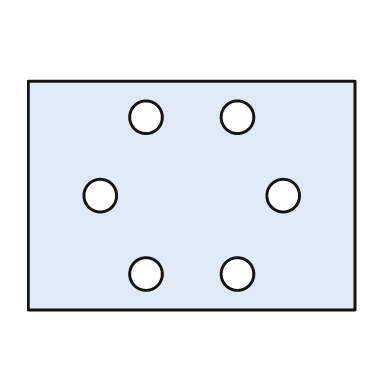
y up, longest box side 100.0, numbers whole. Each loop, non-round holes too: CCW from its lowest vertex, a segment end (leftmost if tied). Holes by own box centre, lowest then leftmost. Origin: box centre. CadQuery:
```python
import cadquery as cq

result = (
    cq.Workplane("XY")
    .moveTo(-50.0, -35.0)
    .lineTo(50.0, -35.0)
    .lineTo(50.0, 35.0)
    .lineTo(-50.0, 35.0)
    .close()
    .moveTo(-14.0, -24.0)
    .circle(5.0)
    .moveTo(14.0, -24.0)
    .circle(5.0)
    .moveTo(-28.0, 0.0)
    .circle(5.0)
    .moveTo(28.0, 0.0)
    .circle(5.0)
    .moveTo(-14.0, 24.0)
    .circle(5.0)
    .moveTo(14.0, 24.0)
    .circle(5.0)
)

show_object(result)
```